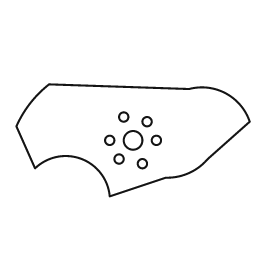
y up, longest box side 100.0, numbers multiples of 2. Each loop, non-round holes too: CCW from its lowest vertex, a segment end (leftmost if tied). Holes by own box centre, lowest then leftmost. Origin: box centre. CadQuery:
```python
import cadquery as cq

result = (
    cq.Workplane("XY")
    .moveTo(-10.0, -24.0)
    .lineTo(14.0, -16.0)
    .threePointArc((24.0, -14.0), (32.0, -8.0))
    .lineTo(50.0, 8.0)
    .threePointArc((40.0, 20.0), (24.0, 22.0))
    .lineTo(-36.0, 24.0)
    .threePointArc((-44.0, 16.0), (-50.0, 6.0))
    .lineTo(-42.0, -12.0)
    .threePointArc((-22.0, -8.0), (-10.0, -24.0))
    .close()
    .moveTo(4.0, -10.0)
    .circle(2.0)
    .moveTo(-6.0, -8.0)
    .circle(2.0)
    .moveTo(-10.0, 0.0)
    .circle(2.0)
    .moveTo(0.0, 0.0)
    .circle(4.0)
    .moveTo(10.0, 0.0)
    .circle(2.0)
    .moveTo(6.0, 8.0)
    .circle(2.0)
    .moveTo(-4.0, 10.0)
    .circle(2.0)
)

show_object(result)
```